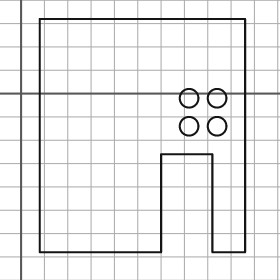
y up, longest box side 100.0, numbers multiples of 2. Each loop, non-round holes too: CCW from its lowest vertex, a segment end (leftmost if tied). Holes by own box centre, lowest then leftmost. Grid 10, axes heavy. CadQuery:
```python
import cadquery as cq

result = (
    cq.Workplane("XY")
    .moveTo(8.0, -68.0)
    .lineTo(60.0, -68.0)
    .lineTo(60.0, -26.0)
    .lineTo(82.0, -26.0)
    .lineTo(82.0, -68.0)
    .lineTo(96.0, -68.0)
    .lineTo(96.0, 32.0)
    .lineTo(8.0, 32.0)
    .close()
    .moveTo(72.0, -14.0)
    .circle(4.0)
    .moveTo(84.0, -14.0)
    .circle(4.0)
    .moveTo(72.0, -2.0)
    .circle(4.0)
    .moveTo(84.0, -2.0)
    .circle(4.0)
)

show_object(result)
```